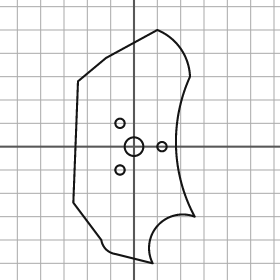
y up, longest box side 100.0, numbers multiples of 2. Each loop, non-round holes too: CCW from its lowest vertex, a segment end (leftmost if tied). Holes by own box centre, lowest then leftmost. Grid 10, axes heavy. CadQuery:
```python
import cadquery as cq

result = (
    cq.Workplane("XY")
    .moveTo(8.0, -50.0)
    .threePointArc((10.0, -34.0), (26.0, -30.0))
    .threePointArc((18.0, 0.0), (24.0, 30.0))
    .threePointArc((20.0, 42.0), (10.0, 50.0))
    .lineTo(-12.0, 38.0)
    .lineTo(-24.0, 28.0)
    .lineTo(-26.0, -24.0)
    .lineTo(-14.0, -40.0)
    .threePointArc((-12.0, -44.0), (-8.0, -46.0))
    .close()
    .moveTo(-6.0, -10.0)
    .circle(2.0)
    .moveTo(0.0, 0.0)
    .circle(4.0)
    .moveTo(12.0, 0.0)
    .circle(2.0)
    .moveTo(-6.0, 10.0)
    .circle(2.0)
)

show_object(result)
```